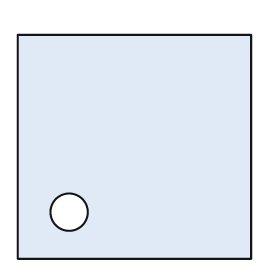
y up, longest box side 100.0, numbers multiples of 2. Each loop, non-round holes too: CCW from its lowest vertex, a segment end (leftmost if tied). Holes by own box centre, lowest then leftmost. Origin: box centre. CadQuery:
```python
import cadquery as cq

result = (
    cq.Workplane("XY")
    .moveTo(-50.0, -48.0)
    .lineTo(50.0, -48.0)
    .lineTo(50.0, 48.0)
    .lineTo(-50.0, 48.0)
    .close()
    .moveTo(-28.0, -28.0)
    .circle(8.0)
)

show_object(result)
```